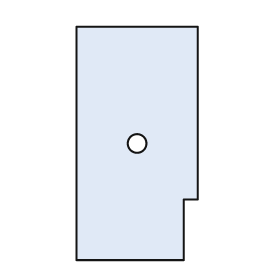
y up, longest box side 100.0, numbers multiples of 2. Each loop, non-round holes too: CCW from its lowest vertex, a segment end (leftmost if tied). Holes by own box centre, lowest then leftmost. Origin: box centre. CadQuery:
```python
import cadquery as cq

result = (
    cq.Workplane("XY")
    .moveTo(-26.0, -50.0)
    .lineTo(20.0, -50.0)
    .lineTo(20.0, -24.0)
    .lineTo(26.0, -24.0)
    .lineTo(26.0, 50.0)
    .lineTo(-26.0, 50.0)
    .close()
    .moveTo(0.0, 0.0)
    .circle(4.0)
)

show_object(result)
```